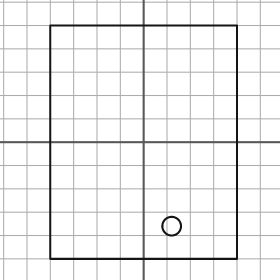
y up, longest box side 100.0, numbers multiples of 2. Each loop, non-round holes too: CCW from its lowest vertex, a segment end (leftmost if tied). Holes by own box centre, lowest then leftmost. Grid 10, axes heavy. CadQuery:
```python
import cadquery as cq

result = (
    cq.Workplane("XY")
    .moveTo(-40.0, -50.0)
    .lineTo(40.0, -50.0)
    .lineTo(40.0, 50.0)
    .lineTo(-40.0, 50.0)
    .close()
    .moveTo(12.0, -36.0)
    .circle(4.0)
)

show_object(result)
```